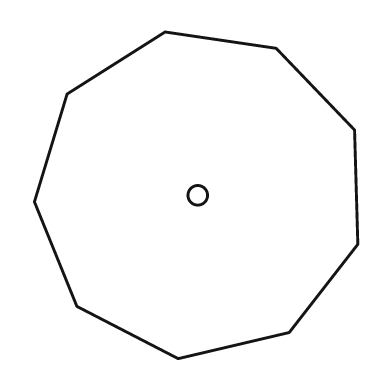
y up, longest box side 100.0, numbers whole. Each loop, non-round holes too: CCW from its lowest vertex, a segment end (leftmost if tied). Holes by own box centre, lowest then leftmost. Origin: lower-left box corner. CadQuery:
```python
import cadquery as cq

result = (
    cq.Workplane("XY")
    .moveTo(44.0, 0.0)
    .lineTo(78.0, 8.0)
    .lineTo(99.0, 35.0)
    .lineTo(98.0, 70.0)
    .lineTo(74.0, 95.0)
    .lineTo(40.0, 100.0)
    .lineTo(10.0, 81.0)
    .lineTo(0.0, 48.0)
    .lineTo(13.0, 16.0)
    .close()
    .moveTo(50.0, 50.0)
    .circle(3.0)
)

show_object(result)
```